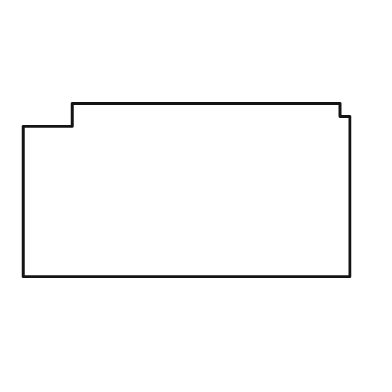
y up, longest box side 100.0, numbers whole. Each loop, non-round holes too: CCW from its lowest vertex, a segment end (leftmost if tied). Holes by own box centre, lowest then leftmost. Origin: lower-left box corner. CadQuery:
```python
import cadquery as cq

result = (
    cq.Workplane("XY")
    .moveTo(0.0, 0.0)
    .lineTo(100.0, 0.0)
    .lineTo(100.0, 49.0)
    .lineTo(97.0, 49.0)
    .lineTo(97.0, 53.0)
    .lineTo(15.0, 53.0)
    .lineTo(15.0, 46.0)
    .lineTo(0.0, 46.0)
    .close()
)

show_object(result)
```